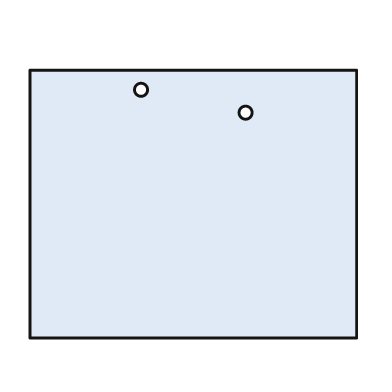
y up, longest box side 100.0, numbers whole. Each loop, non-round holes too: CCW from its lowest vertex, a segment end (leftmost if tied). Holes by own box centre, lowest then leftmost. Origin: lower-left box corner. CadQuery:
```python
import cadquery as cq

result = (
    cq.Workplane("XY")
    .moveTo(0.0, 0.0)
    .lineTo(100.0, 0.0)
    .lineTo(100.0, 82.0)
    .lineTo(0.0, 82.0)
    .close()
    .moveTo(66.0, 69.0)
    .circle(2.0)
    .moveTo(34.0, 76.0)
    .circle(2.0)
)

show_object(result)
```